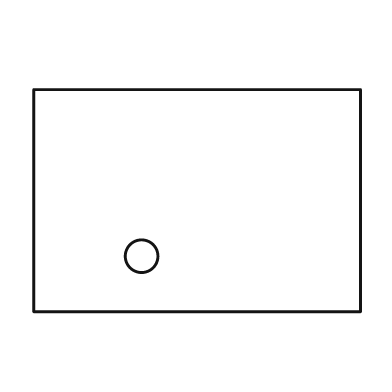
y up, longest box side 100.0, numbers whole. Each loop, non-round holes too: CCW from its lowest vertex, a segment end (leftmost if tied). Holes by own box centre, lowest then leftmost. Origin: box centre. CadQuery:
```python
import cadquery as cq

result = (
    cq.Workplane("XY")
    .moveTo(-50.0, -34.0)
    .lineTo(50.0, -34.0)
    .lineTo(50.0, 34.0)
    .lineTo(-50.0, 34.0)
    .close()
    .moveTo(-17.0, -17.0)
    .circle(5.0)
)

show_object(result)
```